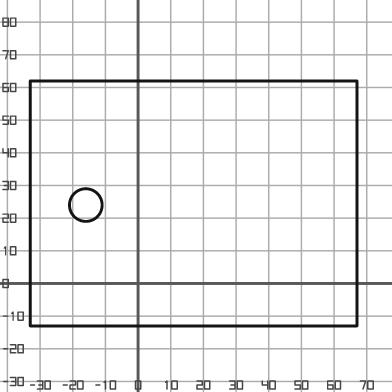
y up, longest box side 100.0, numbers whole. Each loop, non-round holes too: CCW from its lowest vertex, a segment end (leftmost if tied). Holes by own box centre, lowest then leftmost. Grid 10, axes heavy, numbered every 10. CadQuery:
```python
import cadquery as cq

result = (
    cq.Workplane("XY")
    .moveTo(-33.0, -13.0)
    .lineTo(67.0, -13.0)
    .lineTo(67.0, 62.0)
    .lineTo(-33.0, 62.0)
    .close()
    .moveTo(-16.0, 24.0)
    .circle(5.0)
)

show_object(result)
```